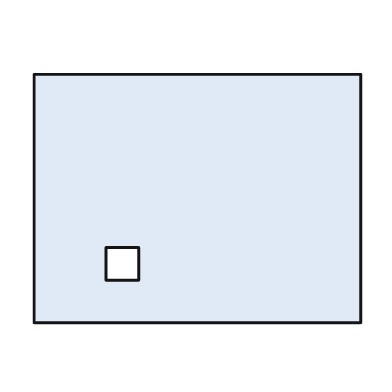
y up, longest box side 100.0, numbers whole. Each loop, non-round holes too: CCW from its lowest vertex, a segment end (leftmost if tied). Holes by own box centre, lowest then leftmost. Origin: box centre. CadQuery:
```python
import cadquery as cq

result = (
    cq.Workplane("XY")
    .moveTo(-50.0, -38.0)
    .lineTo(50.0, -38.0)
    .lineTo(50.0, 38.0)
    .lineTo(-50.0, 38.0)
    .close()
    .moveTo(-28.0, -25.0)
    .lineTo(-18.0, -25.0)
    .lineTo(-18.0, -15.0)
    .lineTo(-28.0, -15.0)
    .close()
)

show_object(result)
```